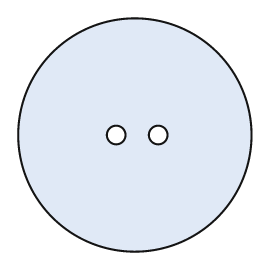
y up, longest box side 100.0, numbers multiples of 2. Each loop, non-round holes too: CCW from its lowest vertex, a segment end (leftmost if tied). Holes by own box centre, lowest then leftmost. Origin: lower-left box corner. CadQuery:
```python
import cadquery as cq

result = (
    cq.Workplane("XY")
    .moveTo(50.0, 50.0)
    .circle(50.0)
    .moveTo(42.0, 50.0)
    .circle(4.0)
    .moveTo(60.0, 50.0)
    .circle(4.0)
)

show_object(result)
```